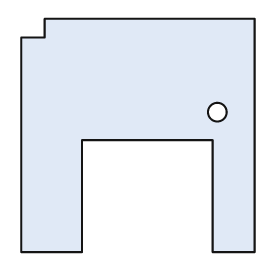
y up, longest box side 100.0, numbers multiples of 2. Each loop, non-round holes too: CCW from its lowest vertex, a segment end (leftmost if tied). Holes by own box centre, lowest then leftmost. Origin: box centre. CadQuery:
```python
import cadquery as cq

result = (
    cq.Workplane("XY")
    .moveTo(-50.0, -50.0)
    .lineTo(-24.0, -50.0)
    .lineTo(-24.0, -2.0)
    .lineTo(32.0, -2.0)
    .lineTo(32.0, -50.0)
    .lineTo(50.0, -50.0)
    .lineTo(50.0, 50.0)
    .lineTo(-40.0, 50.0)
    .lineTo(-40.0, 42.0)
    .lineTo(-50.0, 42.0)
    .close()
    .moveTo(34.0, 10.0)
    .circle(4.0)
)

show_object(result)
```